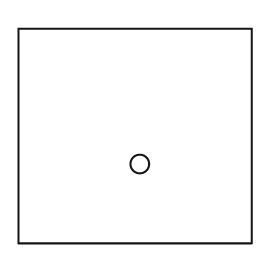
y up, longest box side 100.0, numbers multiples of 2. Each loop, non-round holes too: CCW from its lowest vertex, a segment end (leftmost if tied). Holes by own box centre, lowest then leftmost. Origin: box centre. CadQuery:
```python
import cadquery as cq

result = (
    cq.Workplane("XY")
    .moveTo(-50.0, -46.0)
    .lineTo(50.0, -46.0)
    .lineTo(50.0, 46.0)
    .lineTo(-50.0, 46.0)
    .close()
    .moveTo(2.0, -12.0)
    .circle(4.0)
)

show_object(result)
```